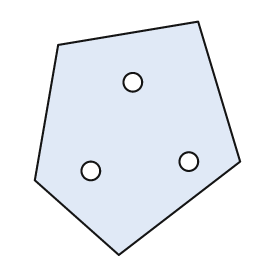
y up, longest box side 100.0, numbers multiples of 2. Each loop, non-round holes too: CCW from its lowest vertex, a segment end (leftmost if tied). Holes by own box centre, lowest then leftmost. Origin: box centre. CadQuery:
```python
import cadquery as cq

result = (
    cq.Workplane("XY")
    .moveTo(-8.0, -50.0)
    .lineTo(44.0, -10.0)
    .lineTo(26.0, 50.0)
    .lineTo(-34.0, 40.0)
    .lineTo(-44.0, -18.0)
    .close()
    .moveTo(-20.0, -14.0)
    .circle(4.0)
    .moveTo(22.0, -10.0)
    .circle(4.0)
    .moveTo(-2.0, 24.0)
    .circle(4.0)
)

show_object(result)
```